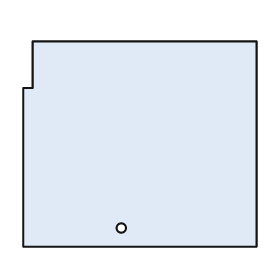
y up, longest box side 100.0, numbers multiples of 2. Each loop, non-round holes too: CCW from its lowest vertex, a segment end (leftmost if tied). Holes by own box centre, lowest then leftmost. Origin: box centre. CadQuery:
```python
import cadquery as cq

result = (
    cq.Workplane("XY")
    .moveTo(-50.0, -44.0)
    .lineTo(50.0, -44.0)
    .lineTo(50.0, 44.0)
    .lineTo(-46.0, 44.0)
    .lineTo(-46.0, 24.0)
    .lineTo(-50.0, 24.0)
    .close()
    .moveTo(-8.0, -36.0)
    .circle(2.0)
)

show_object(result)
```